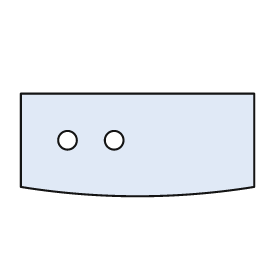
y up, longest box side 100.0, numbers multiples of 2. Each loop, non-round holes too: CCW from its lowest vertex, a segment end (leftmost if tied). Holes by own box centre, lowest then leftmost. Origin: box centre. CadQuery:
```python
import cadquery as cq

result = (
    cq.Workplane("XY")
    .moveTo(-50.0, -18.0)
    .threePointArc((0.0, -22.0), (50.0, -18.0))
    .lineTo(50.0, 22.0)
    .lineTo(-50.0, 22.0)
    .close()
    .moveTo(-30.0, 2.0)
    .circle(4.0)
    .moveTo(-10.0, 2.0)
    .circle(4.0)
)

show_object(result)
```